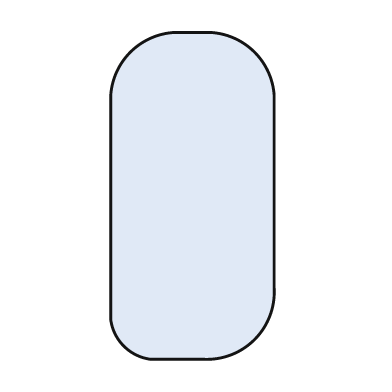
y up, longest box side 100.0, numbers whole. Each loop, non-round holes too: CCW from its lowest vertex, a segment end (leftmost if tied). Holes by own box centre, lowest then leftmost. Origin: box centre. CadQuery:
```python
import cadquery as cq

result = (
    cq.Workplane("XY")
    .moveTo(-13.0, -50.0)
    .lineTo(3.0, -50.0)
    .threePointArc((19.0, -44.0), (25.0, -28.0))
    .lineTo(25.0, 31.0)
    .threePointArc((19.0, 44.0), (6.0, 50.0))
    .lineTo(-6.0, 50.0)
    .threePointArc((-19.0, 44.0), (-25.0, 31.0))
    .lineTo(-25.0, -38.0)
    .threePointArc((-21.0, -46.0), (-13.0, -50.0))
    .close()
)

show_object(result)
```